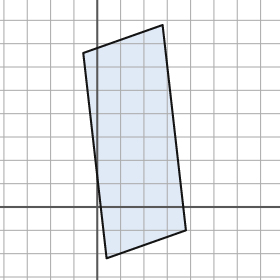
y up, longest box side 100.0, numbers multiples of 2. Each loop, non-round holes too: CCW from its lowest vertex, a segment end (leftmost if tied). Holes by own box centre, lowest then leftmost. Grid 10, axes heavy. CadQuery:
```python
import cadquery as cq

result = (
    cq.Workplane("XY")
    .moveTo(4.0, -22.0)
    .lineTo(38.0, -10.0)
    .lineTo(28.0, 78.0)
    .lineTo(-6.0, 66.0)
    .close()
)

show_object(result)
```